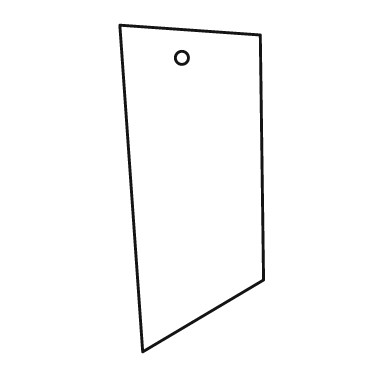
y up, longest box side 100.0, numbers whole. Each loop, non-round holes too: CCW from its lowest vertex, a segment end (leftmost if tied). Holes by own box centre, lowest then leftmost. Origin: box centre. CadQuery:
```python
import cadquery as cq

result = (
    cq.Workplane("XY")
    .moveTo(-15.0, -50.0)
    .lineTo(22.0, -28.0)
    .lineTo(21.0, 47.0)
    .lineTo(-22.0, 50.0)
    .close()
    .moveTo(-3.0, 40.0)
    .circle(2.0)
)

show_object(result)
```